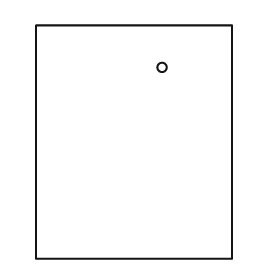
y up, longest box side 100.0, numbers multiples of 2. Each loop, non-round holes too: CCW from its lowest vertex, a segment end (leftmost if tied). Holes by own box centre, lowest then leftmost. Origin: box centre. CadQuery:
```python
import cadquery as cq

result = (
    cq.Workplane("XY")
    .moveTo(-42.0, -50.0)
    .lineTo(42.0, -50.0)
    .lineTo(42.0, 50.0)
    .lineTo(-42.0, 50.0)
    .close()
    .moveTo(12.0, 32.0)
    .circle(2.0)
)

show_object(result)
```